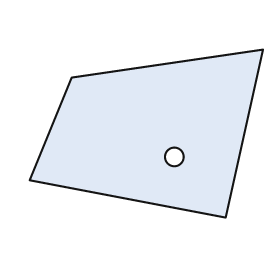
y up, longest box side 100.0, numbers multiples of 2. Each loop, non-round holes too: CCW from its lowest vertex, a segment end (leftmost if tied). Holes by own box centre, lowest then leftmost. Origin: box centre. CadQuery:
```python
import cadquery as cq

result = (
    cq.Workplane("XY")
    .moveTo(34.0, -36.0)
    .lineTo(50.0, 36.0)
    .lineTo(-32.0, 24.0)
    .lineTo(-50.0, -20.0)
    .close()
    .moveTo(12.0, -10.0)
    .circle(4.0)
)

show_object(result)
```